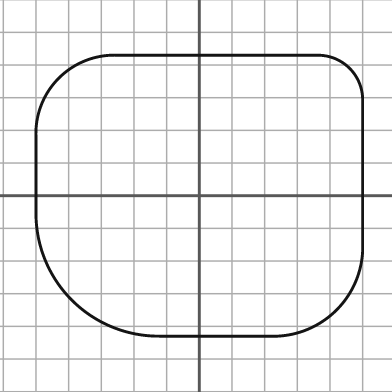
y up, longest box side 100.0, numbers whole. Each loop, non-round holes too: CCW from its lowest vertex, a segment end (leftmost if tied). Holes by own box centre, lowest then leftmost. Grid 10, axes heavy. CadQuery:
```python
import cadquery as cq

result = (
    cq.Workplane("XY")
    .moveTo(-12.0, -43.0)
    .lineTo(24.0, -43.0)
    .threePointArc((42.0, -35.0), (50.0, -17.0))
    .lineTo(50.0, 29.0)
    .threePointArc((46.0, 39.0), (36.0, 43.0))
    .lineTo(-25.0, 43.0)
    .threePointArc((-43.0, 36.0), (-50.0, 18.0))
    .lineTo(-50.0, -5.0)
    .threePointArc((-39.0, -32.0), (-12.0, -43.0))
    .close()
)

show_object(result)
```